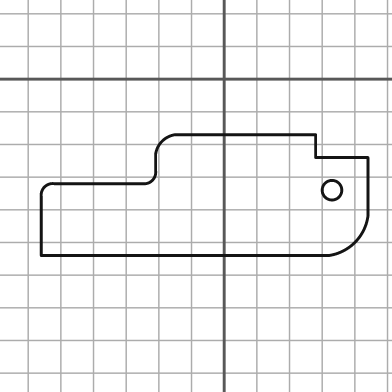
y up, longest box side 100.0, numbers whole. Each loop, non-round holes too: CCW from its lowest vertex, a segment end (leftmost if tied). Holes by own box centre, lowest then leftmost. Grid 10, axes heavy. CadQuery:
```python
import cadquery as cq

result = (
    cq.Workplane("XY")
    .moveTo(-56.0, -54.0)
    .lineTo(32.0, -54.0)
    .threePointArc((40.0, -50.0), (44.0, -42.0))
    .lineTo(44.0, -24.0)
    .lineTo(28.0, -24.0)
    .lineTo(28.0, -17.0)
    .lineTo(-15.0, -17.0)
    .threePointArc((-19.0, -19.0), (-21.0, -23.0))
    .lineTo(-21.0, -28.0)
    .threePointArc((-22.0, -31.0), (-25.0, -32.0))
    .lineTo(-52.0, -32.0)
    .threePointArc((-55.0, -33.0), (-56.0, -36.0))
    .close()
    .moveTo(33.0, -34.0)
    .circle(3.0)
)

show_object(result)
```